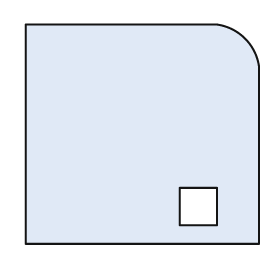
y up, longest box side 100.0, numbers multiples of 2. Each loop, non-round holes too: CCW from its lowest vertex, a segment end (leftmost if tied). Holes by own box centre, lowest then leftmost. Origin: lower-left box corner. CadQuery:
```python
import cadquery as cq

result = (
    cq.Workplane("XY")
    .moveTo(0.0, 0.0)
    .lineTo(100.0, 0.0)
    .lineTo(100.0, 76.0)
    .threePointArc((94.0, 88.0), (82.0, 94.0))
    .lineTo(0.0, 94.0)
    .close()
    .moveTo(66.0, 8.0)
    .lineTo(82.0, 8.0)
    .lineTo(82.0, 24.0)
    .lineTo(66.0, 24.0)
    .close()
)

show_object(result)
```